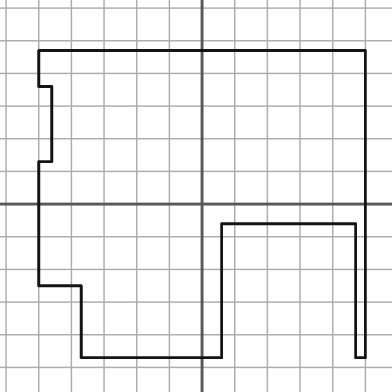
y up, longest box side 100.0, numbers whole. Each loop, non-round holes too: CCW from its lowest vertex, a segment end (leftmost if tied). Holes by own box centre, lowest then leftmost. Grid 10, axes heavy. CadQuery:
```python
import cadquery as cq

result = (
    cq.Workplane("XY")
    .moveTo(-37.0, -47.0)
    .lineTo(6.0, -47.0)
    .lineTo(6.0, -6.0)
    .lineTo(47.0, -6.0)
    .lineTo(47.0, -47.0)
    .lineTo(50.0, -47.0)
    .lineTo(50.0, 47.0)
    .lineTo(-50.0, 47.0)
    .lineTo(-50.0, 36.0)
    .lineTo(-46.0, 36.0)
    .lineTo(-46.0, 13.0)
    .lineTo(-50.0, 13.0)
    .lineTo(-50.0, -25.0)
    .lineTo(-37.0, -25.0)
    .close()
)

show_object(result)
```